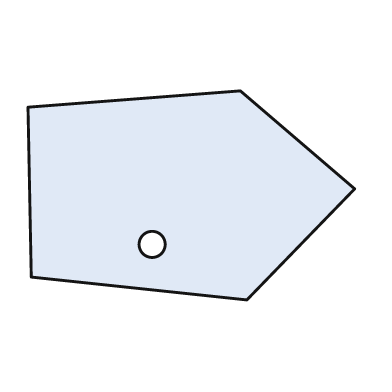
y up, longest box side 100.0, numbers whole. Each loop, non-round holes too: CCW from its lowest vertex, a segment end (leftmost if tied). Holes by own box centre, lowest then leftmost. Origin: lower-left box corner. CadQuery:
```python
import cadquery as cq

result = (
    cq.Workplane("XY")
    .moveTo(67.0, 0.0)
    .lineTo(100.0, 34.0)
    .lineTo(65.0, 64.0)
    .lineTo(0.0, 59.0)
    .lineTo(1.0, 7.0)
    .close()
    .moveTo(38.0, 17.0)
    .circle(4.0)
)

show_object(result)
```